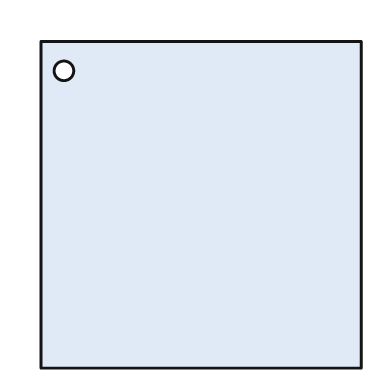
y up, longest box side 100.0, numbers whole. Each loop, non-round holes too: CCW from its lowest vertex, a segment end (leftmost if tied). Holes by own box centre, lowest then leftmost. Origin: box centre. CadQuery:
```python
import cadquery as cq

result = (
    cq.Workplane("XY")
    .moveTo(-49.0, -50.0)
    .lineTo(49.0, -50.0)
    .lineTo(49.0, 50.0)
    .lineTo(-49.0, 50.0)
    .close()
    .moveTo(-42.0, 41.0)
    .circle(3.0)
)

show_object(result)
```